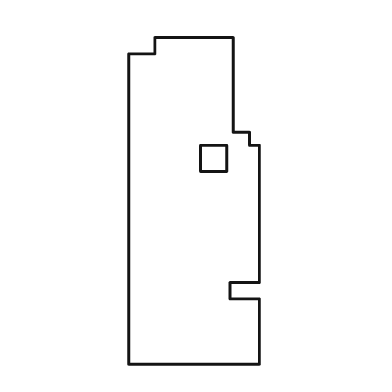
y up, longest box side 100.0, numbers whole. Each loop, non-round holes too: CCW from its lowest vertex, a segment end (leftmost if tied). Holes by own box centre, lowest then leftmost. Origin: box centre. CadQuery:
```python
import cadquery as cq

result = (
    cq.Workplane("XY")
    .moveTo(-20.0, -50.0)
    .lineTo(20.0, -50.0)
    .lineTo(20.0, -30.0)
    .lineTo(11.0, -30.0)
    .lineTo(11.0, -25.0)
    .lineTo(20.0, -25.0)
    .lineTo(20.0, 17.0)
    .lineTo(17.0, 17.0)
    .lineTo(17.0, 21.0)
    .lineTo(12.0, 21.0)
    .lineTo(12.0, 50.0)
    .lineTo(-12.0, 50.0)
    .lineTo(-12.0, 45.0)
    .lineTo(-20.0, 45.0)
    .close()
    .moveTo(2.0, 9.0)
    .lineTo(10.0, 9.0)
    .lineTo(10.0, 17.0)
    .lineTo(2.0, 17.0)
    .close()
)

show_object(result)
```